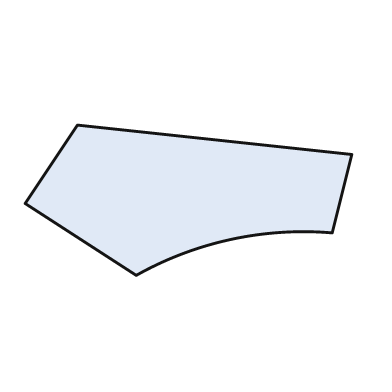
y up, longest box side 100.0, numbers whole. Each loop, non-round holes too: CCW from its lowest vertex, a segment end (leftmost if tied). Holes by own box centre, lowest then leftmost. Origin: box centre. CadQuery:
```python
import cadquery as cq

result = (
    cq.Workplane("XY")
    .moveTo(-16.0, -23.0)
    .threePointArc((13.0, -12.0), (44.0, -10.0))
    .lineTo(50.0, 14.0)
    .lineTo(-34.0, 23.0)
    .lineTo(-50.0, -1.0)
    .close()
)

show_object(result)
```